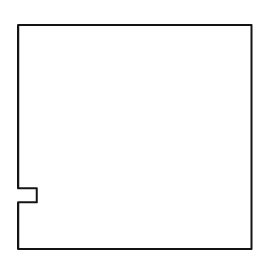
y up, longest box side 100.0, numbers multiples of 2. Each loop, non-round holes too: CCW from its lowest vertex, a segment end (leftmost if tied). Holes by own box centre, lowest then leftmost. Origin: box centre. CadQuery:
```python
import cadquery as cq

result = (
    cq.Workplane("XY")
    .moveTo(-50.0, -48.0)
    .lineTo(50.0, -48.0)
    .lineTo(50.0, 48.0)
    .lineTo(-50.0, 48.0)
    .lineTo(-50.0, -22.0)
    .lineTo(-42.0, -22.0)
    .lineTo(-42.0, -28.0)
    .lineTo(-50.0, -28.0)
    .close()
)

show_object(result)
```